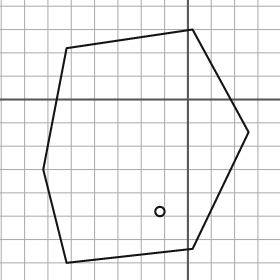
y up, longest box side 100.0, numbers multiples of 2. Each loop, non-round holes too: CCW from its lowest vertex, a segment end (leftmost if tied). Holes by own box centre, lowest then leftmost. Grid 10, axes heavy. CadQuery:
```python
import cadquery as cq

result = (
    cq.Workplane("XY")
    .moveTo(-52.0, -70.0)
    .lineTo(2.0, -64.0)
    .lineTo(26.0, -14.0)
    .lineTo(2.0, 30.0)
    .lineTo(-52.0, 22.0)
    .lineTo(-62.0, -30.0)
    .close()
    .moveTo(-12.0, -48.0)
    .circle(2.0)
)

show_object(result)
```